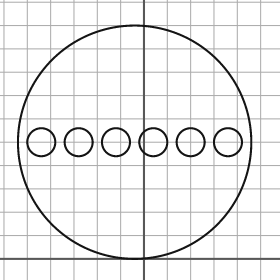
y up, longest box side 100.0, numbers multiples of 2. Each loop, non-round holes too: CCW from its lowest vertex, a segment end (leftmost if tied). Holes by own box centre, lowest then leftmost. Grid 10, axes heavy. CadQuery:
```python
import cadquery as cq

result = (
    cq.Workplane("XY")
    .moveTo(-4.0, 50.0)
    .circle(50.0)
    .moveTo(-44.0, 50.0)
    .circle(6.0)
    .moveTo(-28.0, 50.0)
    .circle(6.0)
    .moveTo(-12.0, 50.0)
    .circle(6.0)
    .moveTo(4.0, 50.0)
    .circle(6.0)
    .moveTo(20.0, 50.0)
    .circle(6.0)
    .moveTo(36.0, 50.0)
    .circle(6.0)
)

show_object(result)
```